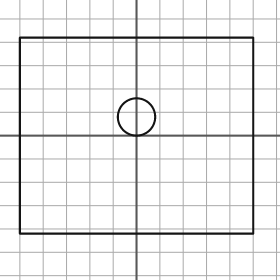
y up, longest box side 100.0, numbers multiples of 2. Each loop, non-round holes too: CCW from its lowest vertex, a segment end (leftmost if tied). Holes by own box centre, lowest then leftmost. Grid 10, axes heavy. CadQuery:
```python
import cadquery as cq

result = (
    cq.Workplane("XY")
    .moveTo(-50.0, -42.0)
    .lineTo(50.0, -42.0)
    .lineTo(50.0, 42.0)
    .lineTo(-50.0, 42.0)
    .close()
    .moveTo(0.0, 8.0)
    .circle(8.0)
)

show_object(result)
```